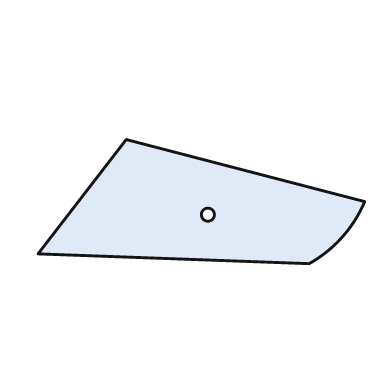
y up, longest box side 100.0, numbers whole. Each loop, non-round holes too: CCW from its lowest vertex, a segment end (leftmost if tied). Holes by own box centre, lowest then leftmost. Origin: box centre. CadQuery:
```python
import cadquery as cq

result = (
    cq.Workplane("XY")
    .moveTo(33.0, -19.0)
    .threePointArc((43.0, -11.0), (50.0, 0.0))
    .lineTo(-23.0, 19.0)
    .lineTo(-50.0, -16.0)
    .close()
    .moveTo(2.0, -4.0)
    .circle(2.0)
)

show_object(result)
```